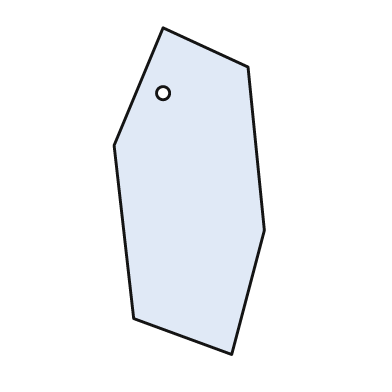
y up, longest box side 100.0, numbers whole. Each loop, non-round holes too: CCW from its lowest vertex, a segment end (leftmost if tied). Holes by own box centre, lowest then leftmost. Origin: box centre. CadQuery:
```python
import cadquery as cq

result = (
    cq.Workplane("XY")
    .moveTo(13.0, -50.0)
    .lineTo(23.0, -12.0)
    .lineTo(18.0, 38.0)
    .lineTo(-8.0, 50.0)
    .lineTo(-23.0, 14.0)
    .lineTo(-17.0, -39.0)
    .close()
    .moveTo(-8.0, 30.0)
    .circle(2.0)
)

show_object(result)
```